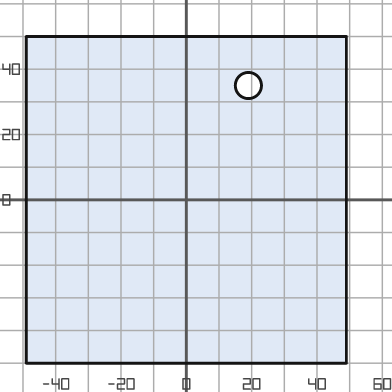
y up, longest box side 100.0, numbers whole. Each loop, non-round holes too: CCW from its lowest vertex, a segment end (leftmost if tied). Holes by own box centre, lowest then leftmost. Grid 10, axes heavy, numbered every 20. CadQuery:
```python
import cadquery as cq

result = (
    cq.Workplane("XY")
    .moveTo(-49.0, -50.0)
    .lineTo(49.0, -50.0)
    .lineTo(49.0, 50.0)
    .lineTo(-49.0, 50.0)
    .close()
    .moveTo(19.0, 35.0)
    .circle(4.0)
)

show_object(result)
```